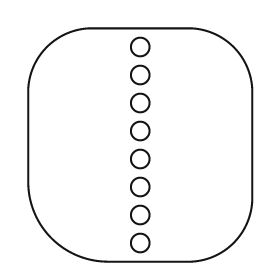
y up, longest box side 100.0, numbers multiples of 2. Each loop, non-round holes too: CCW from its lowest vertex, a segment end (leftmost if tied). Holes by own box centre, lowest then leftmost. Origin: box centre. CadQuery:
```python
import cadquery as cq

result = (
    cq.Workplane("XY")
    .moveTo(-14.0, -50.0)
    .lineTo(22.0, -50.0)
    .threePointArc((40.0, -42.0), (48.0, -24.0))
    .lineTo(48.0, 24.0)
    .threePointArc((40.0, 42.0), (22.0, 50.0))
    .lineTo(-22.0, 50.0)
    .threePointArc((-40.0, 42.0), (-48.0, 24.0))
    .lineTo(-48.0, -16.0)
    .threePointArc((-38.0, -40.0), (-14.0, -50.0))
    .close()
    .moveTo(0.0, -42.0)
    .circle(4.0)
    .moveTo(0.0, -30.0)
    .circle(4.0)
    .moveTo(0.0, -18.0)
    .circle(4.0)
    .moveTo(0.0, -6.0)
    .circle(4.0)
    .moveTo(0.0, 6.0)
    .circle(4.0)
    .moveTo(0.0, 18.0)
    .circle(4.0)
    .moveTo(0.0, 30.0)
    .circle(4.0)
    .moveTo(0.0, 42.0)
    .circle(4.0)
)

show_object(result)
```